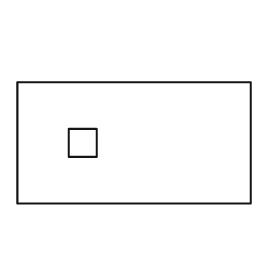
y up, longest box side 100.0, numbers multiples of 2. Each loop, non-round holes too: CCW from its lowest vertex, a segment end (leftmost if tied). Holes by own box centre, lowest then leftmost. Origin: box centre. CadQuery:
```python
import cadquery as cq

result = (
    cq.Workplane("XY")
    .moveTo(-50.0, -26.0)
    .lineTo(50.0, -26.0)
    .lineTo(50.0, 26.0)
    .lineTo(-50.0, 26.0)
    .close()
    .moveTo(-28.0, -6.0)
    .lineTo(-16.0, -6.0)
    .lineTo(-16.0, 6.0)
    .lineTo(-28.0, 6.0)
    .close()
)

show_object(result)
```